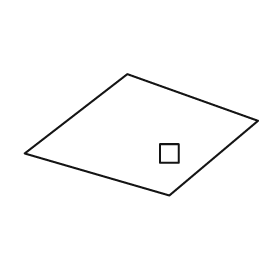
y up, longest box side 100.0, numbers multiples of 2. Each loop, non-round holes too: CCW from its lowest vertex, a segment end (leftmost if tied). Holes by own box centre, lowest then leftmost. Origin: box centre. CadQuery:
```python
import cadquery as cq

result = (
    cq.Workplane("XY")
    .moveTo(12.0, -26.0)
    .lineTo(50.0, 6.0)
    .lineTo(-6.0, 26.0)
    .lineTo(-50.0, -8.0)
    .close()
    .moveTo(8.0, -12.0)
    .lineTo(16.0, -12.0)
    .lineTo(16.0, -4.0)
    .lineTo(8.0, -4.0)
    .close()
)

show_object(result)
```